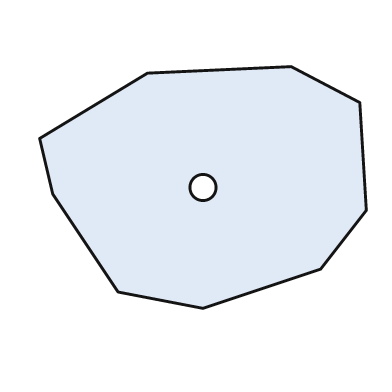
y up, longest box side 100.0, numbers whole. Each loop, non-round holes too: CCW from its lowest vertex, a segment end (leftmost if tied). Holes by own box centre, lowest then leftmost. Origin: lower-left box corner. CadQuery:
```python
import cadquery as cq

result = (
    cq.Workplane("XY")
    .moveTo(50.0, 0.0)
    .lineTo(86.0, 12.0)
    .lineTo(100.0, 30.0)
    .lineTo(98.0, 63.0)
    .lineTo(77.0, 74.0)
    .lineTo(33.0, 72.0)
    .lineTo(0.0, 52.0)
    .lineTo(4.0, 35.0)
    .lineTo(24.0, 5.0)
    .close()
    .moveTo(50.0, 37.0)
    .circle(4.0)
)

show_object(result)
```